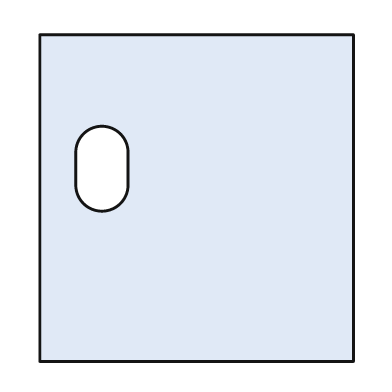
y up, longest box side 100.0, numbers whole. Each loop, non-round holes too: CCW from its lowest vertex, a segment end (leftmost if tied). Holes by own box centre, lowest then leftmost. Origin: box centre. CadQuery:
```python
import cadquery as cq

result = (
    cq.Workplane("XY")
    .moveTo(-48.0, -50.0)
    .lineTo(48.0, -50.0)
    .lineTo(48.0, 50.0)
    .lineTo(-48.0, 50.0)
    .close()
    .moveTo(-37.0, 4.0)
    .threePointArc((-29.0, -4.0), (-21.0, 4.0))
    .lineTo(-21.0, 14.0)
    .threePointArc((-29.0, 22.0), (-37.0, 14.0))
    .close()
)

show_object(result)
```